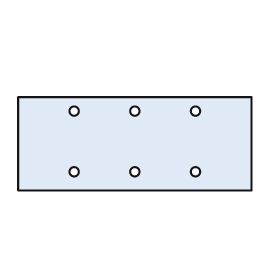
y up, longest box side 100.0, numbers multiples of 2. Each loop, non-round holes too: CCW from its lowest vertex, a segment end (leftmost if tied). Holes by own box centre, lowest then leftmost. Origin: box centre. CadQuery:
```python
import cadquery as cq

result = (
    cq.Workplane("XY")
    .moveTo(-50.0, -20.0)
    .lineTo(50.0, -20.0)
    .lineTo(50.0, 20.0)
    .lineTo(-50.0, 20.0)
    .close()
    .moveTo(-26.0, -12.0)
    .circle(2.0)
    .moveTo(0.0, -12.0)
    .circle(2.0)
    .moveTo(26.0, -12.0)
    .circle(2.0)
    .moveTo(-26.0, 14.0)
    .circle(2.0)
    .moveTo(0.0, 14.0)
    .circle(2.0)
    .moveTo(26.0, 14.0)
    .circle(2.0)
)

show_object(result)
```